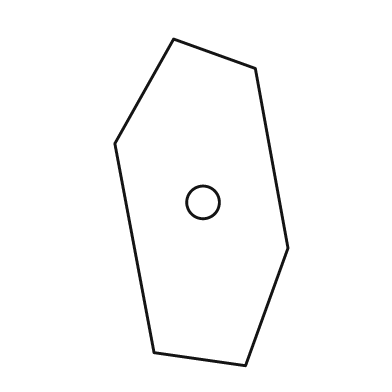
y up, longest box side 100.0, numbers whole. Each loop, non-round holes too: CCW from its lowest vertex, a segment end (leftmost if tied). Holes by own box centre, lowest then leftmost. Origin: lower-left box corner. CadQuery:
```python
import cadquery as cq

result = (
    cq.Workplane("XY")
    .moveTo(40.0, 0.0)
    .lineTo(53.0, 36.0)
    .lineTo(43.0, 91.0)
    .lineTo(18.0, 100.0)
    .lineTo(0.0, 68.0)
    .lineTo(12.0, 4.0)
    .close()
    .moveTo(27.0, 50.0)
    .circle(5.0)
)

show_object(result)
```